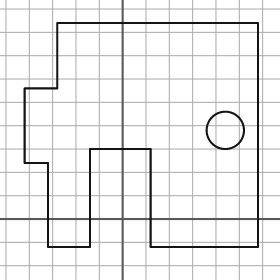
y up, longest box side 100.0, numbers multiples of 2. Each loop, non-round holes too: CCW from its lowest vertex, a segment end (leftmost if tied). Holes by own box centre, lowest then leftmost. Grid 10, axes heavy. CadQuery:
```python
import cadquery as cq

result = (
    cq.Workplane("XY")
    .moveTo(-32.0, -12.0)
    .lineTo(-14.0, -12.0)
    .lineTo(-14.0, 30.0)
    .lineTo(12.0, 30.0)
    .lineTo(12.0, -12.0)
    .lineTo(58.0, -12.0)
    .lineTo(58.0, 84.0)
    .lineTo(-28.0, 84.0)
    .lineTo(-28.0, 56.0)
    .lineTo(-42.0, 56.0)
    .lineTo(-42.0, 24.0)
    .lineTo(-32.0, 24.0)
    .close()
    .moveTo(44.0, 38.0)
    .circle(8.0)
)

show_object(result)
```